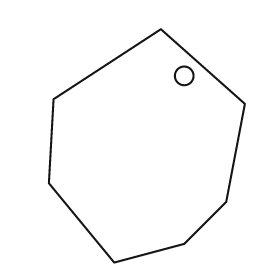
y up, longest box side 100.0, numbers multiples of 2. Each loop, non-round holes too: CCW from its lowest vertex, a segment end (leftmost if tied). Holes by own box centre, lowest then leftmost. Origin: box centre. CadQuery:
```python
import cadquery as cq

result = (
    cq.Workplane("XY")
    .moveTo(-14.0, -50.0)
    .lineTo(16.0, -42.0)
    .lineTo(34.0, -24.0)
    .lineTo(42.0, 18.0)
    .lineTo(6.0, 50.0)
    .lineTo(-40.0, 20.0)
    .lineTo(-42.0, -16.0)
    .close()
    .moveTo(16.0, 30.0)
    .circle(4.0)
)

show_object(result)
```